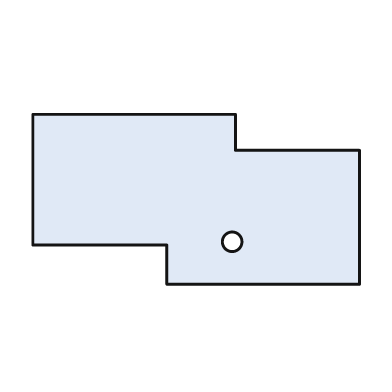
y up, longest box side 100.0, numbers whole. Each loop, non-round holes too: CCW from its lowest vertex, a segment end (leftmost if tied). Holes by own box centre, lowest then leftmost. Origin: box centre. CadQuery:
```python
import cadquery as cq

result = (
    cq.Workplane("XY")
    .moveTo(-9.0, -26.0)
    .lineTo(50.0, -26.0)
    .lineTo(50.0, 15.0)
    .lineTo(12.0, 15.0)
    .lineTo(12.0, 26.0)
    .lineTo(-50.0, 26.0)
    .lineTo(-50.0, -14.0)
    .lineTo(-9.0, -14.0)
    .close()
    .moveTo(11.0, -13.0)
    .circle(3.0)
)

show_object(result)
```